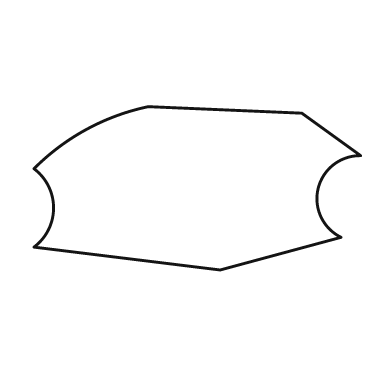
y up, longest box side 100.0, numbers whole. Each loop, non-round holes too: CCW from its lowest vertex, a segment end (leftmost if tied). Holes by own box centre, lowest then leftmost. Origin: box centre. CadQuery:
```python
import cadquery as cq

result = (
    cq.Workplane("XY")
    .moveTo(7.0, -25.0)
    .lineTo(44.0, -15.0)
    .threePointArc((37.0, 0.0), (50.0, 10.0))
    .lineTo(32.0, 23.0)
    .lineTo(-15.0, 25.0)
    .threePointArc((-34.0, 18.0), (-50.0, 6.0))
    .threePointArc((-44.0, -6.0), (-50.0, -18.0))
    .close()
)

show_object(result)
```